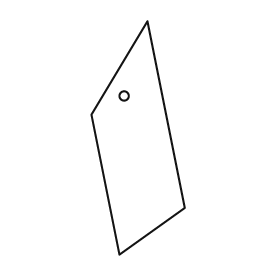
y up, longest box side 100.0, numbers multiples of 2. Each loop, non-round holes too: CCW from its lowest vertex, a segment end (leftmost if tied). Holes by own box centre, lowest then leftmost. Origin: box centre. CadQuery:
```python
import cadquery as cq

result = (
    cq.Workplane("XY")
    .moveTo(-8.0, -50.0)
    .lineTo(20.0, -30.0)
    .lineTo(4.0, 50.0)
    .lineTo(-20.0, 10.0)
    .close()
    .moveTo(-6.0, 18.0)
    .circle(2.0)
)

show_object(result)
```